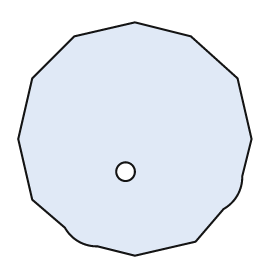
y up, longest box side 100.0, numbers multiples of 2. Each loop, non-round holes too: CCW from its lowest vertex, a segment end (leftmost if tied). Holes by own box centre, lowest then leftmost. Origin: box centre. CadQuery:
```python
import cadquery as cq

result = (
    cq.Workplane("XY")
    .moveTo(0.0, -50.0)
    .lineTo(26.0, -44.0)
    .lineTo(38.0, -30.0)
    .threePointArc((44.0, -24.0), (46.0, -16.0))
    .lineTo(50.0, 0.0)
    .lineTo(44.0, 26.0)
    .lineTo(24.0, 44.0)
    .lineTo(0.0, 50.0)
    .lineTo(-26.0, 44.0)
    .lineTo(-44.0, 26.0)
    .lineTo(-50.0, 0.0)
    .lineTo(-44.0, -26.0)
    .lineTo(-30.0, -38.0)
    .threePointArc((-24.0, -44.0), (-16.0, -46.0))
    .close()
    .moveTo(-4.0, -14.0)
    .circle(4.0)
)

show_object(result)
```